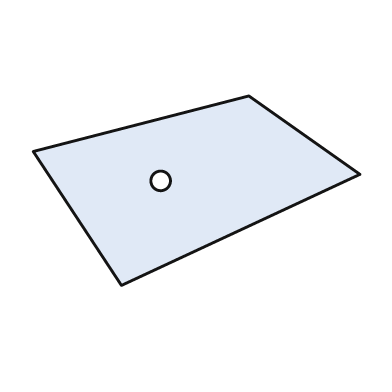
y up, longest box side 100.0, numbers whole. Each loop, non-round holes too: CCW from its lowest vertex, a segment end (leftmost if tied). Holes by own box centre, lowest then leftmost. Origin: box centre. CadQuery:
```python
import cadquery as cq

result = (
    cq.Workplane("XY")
    .moveTo(-23.0, -29.0)
    .lineTo(50.0, 5.0)
    .lineTo(16.0, 29.0)
    .lineTo(-50.0, 12.0)
    .close()
    .moveTo(-11.0, 3.0)
    .circle(3.0)
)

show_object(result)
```